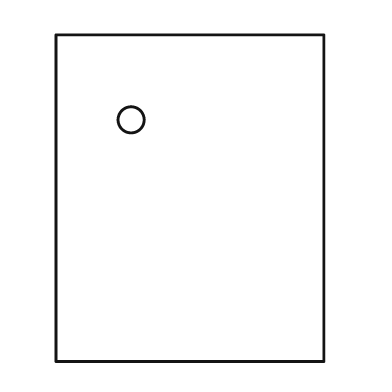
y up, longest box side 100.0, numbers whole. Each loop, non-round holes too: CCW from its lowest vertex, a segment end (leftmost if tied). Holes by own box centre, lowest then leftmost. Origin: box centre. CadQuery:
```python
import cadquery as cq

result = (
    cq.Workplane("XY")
    .moveTo(-41.0, -50.0)
    .lineTo(41.0, -50.0)
    .lineTo(41.0, 50.0)
    .lineTo(-41.0, 50.0)
    .close()
    .moveTo(-18.0, 24.0)
    .circle(4.0)
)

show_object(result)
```